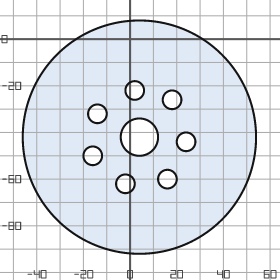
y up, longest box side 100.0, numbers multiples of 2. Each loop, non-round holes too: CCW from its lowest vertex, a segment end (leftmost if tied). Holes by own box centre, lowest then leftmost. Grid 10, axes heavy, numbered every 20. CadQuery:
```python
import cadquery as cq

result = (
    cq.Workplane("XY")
    .moveTo(4.0, -42.0)
    .circle(50.0)
    .moveTo(-2.0, -62.0)
    .circle(4.0)
    .moveTo(16.0, -60.0)
    .circle(4.0)
    .moveTo(-16.0, -50.0)
    .circle(4.0)
    .moveTo(24.0, -44.0)
    .circle(4.0)
    .moveTo(4.0, -42.0)
    .circle(8.0)
    .moveTo(-14.0, -32.0)
    .circle(4.0)
    .moveTo(18.0, -26.0)
    .circle(4.0)
    .moveTo(2.0, -22.0)
    .circle(4.0)
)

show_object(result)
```